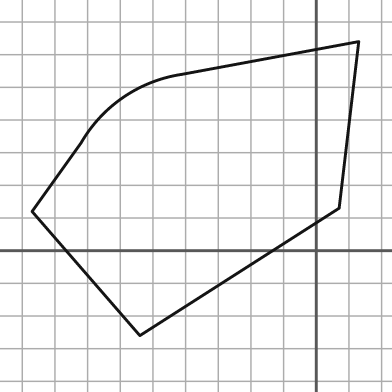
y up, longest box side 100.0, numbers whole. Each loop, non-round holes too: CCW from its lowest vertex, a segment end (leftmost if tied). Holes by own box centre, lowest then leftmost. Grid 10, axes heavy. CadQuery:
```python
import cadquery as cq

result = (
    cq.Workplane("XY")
    .moveTo(-54.0, -26.0)
    .lineTo(7.0, 13.0)
    .lineTo(13.0, 64.0)
    .lineTo(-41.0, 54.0)
    .threePointArc((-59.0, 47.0), (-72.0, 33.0))
    .lineTo(-87.0, 12.0)
    .close()
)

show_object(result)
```